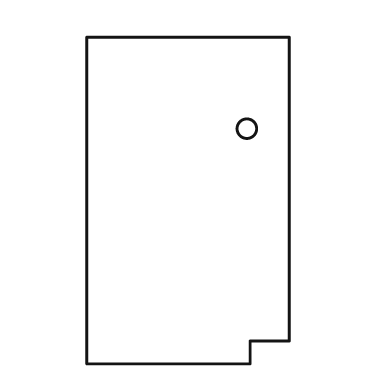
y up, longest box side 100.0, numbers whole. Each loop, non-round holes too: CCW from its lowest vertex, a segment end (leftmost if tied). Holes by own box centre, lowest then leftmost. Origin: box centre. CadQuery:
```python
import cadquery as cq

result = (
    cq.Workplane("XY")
    .moveTo(-31.0, -50.0)
    .lineTo(19.0, -50.0)
    .lineTo(19.0, -43.0)
    .lineTo(31.0, -43.0)
    .lineTo(31.0, 50.0)
    .lineTo(-31.0, 50.0)
    .close()
    .moveTo(18.0, 22.0)
    .circle(3.0)
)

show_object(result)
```